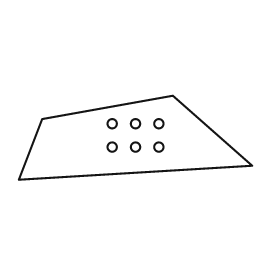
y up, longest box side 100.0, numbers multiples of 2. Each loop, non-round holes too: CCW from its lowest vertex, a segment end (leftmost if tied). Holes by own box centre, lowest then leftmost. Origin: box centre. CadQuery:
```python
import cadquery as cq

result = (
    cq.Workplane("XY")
    .moveTo(-50.0, -18.0)
    .lineTo(50.0, -12.0)
    .lineTo(16.0, 18.0)
    .lineTo(-40.0, 8.0)
    .close()
    .moveTo(-10.0, -4.0)
    .circle(2.0)
    .moveTo(0.0, -4.0)
    .circle(2.0)
    .moveTo(10.0, -4.0)
    .circle(2.0)
    .moveTo(-10.0, 6.0)
    .circle(2.0)
    .moveTo(0.0, 6.0)
    .circle(2.0)
    .moveTo(10.0, 6.0)
    .circle(2.0)
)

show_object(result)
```